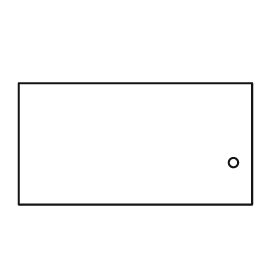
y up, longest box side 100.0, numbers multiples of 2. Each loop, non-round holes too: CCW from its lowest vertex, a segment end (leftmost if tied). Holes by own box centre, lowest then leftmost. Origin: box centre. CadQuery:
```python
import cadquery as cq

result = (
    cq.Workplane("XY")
    .moveTo(-50.0, -26.0)
    .lineTo(50.0, -26.0)
    .lineTo(50.0, 26.0)
    .lineTo(-50.0, 26.0)
    .close()
    .moveTo(42.0, -8.0)
    .circle(2.0)
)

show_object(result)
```